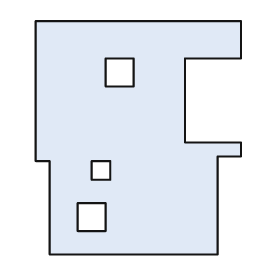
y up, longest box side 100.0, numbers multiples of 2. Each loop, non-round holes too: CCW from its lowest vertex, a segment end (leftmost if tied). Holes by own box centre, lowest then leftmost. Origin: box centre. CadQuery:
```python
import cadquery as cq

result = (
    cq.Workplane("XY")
    .moveTo(-38.0, -50.0)
    .lineTo(34.0, -50.0)
    .lineTo(34.0, -8.0)
    .lineTo(44.0, -8.0)
    .lineTo(44.0, -2.0)
    .lineTo(20.0, -2.0)
    .lineTo(20.0, 34.0)
    .lineTo(44.0, 34.0)
    .lineTo(44.0, 50.0)
    .lineTo(-44.0, 50.0)
    .lineTo(-44.0, -10.0)
    .lineTo(-38.0, -10.0)
    .close()
    .moveTo(-26.0, -40.0)
    .lineTo(-14.0, -40.0)
    .lineTo(-14.0, -28.0)
    .lineTo(-26.0, -28.0)
    .close()
    .moveTo(-20.0, -18.0)
    .lineTo(-12.0, -18.0)
    .lineTo(-12.0, -10.0)
    .lineTo(-20.0, -10.0)
    .close()
    .moveTo(-14.0, 22.0)
    .lineTo(-2.0, 22.0)
    .lineTo(-2.0, 34.0)
    .lineTo(-14.0, 34.0)
    .close()
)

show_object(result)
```